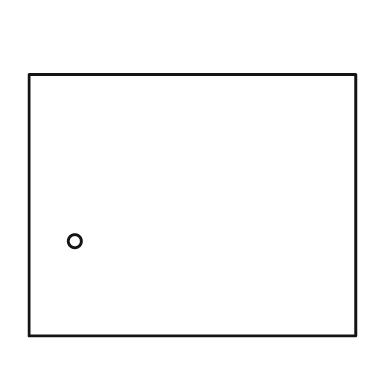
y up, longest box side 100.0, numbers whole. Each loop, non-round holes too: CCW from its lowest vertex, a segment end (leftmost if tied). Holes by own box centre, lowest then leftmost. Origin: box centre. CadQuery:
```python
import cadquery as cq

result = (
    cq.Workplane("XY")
    .moveTo(-50.0, -40.0)
    .lineTo(50.0, -40.0)
    .lineTo(50.0, 40.0)
    .lineTo(-50.0, 40.0)
    .close()
    .moveTo(-36.0, -11.0)
    .circle(2.0)
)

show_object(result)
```